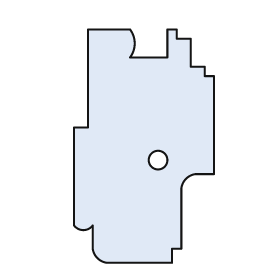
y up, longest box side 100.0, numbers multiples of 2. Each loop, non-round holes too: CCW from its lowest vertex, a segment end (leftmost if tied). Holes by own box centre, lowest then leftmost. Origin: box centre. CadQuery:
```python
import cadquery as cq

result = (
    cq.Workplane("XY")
    .moveTo(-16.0, -50.0)
    .lineTo(12.0, -50.0)
    .lineTo(12.0, -44.0)
    .lineTo(16.0, -44.0)
    .lineTo(16.0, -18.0)
    .threePointArc((18.0, -14.0), (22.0, -12.0))
    .lineTo(30.0, -12.0)
    .lineTo(30.0, 30.0)
    .lineTo(26.0, 30.0)
    .lineTo(26.0, 34.0)
    .lineTo(20.0, 34.0)
    .lineTo(20.0, 46.0)
    .lineTo(14.0, 46.0)
    .lineTo(14.0, 50.0)
    .lineTo(10.0, 50.0)
    .lineTo(10.0, 38.0)
    .lineTo(-6.0, 38.0)
    .threePointArc((-4.0, 44.0), (-6.0, 50.0))
    .lineTo(-24.0, 50.0)
    .lineTo(-24.0, 8.0)
    .lineTo(-30.0, 8.0)
    .lineTo(-30.0, -34.0)
    .threePointArc((-26.0, -36.0), (-22.0, -34.0))
    .lineTo(-22.0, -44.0)
    .threePointArc((-20.0, -48.0), (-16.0, -50.0))
    .close()
    .moveTo(6.0, -6.0)
    .circle(4.0)
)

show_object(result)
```